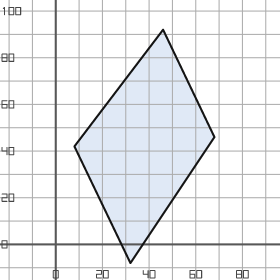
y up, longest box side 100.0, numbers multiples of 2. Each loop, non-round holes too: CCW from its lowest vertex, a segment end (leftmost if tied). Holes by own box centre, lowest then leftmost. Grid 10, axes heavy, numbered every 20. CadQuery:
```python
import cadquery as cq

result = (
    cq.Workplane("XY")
    .moveTo(32.0, -8.0)
    .lineTo(68.0, 46.0)
    .lineTo(46.0, 92.0)
    .lineTo(8.0, 42.0)
    .close()
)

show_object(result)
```